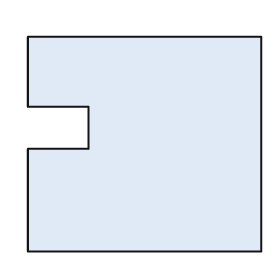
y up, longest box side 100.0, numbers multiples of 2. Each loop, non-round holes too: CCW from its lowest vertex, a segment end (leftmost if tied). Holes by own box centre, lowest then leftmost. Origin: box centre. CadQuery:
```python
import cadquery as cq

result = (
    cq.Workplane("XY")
    .moveTo(-50.0, -46.0)
    .lineTo(50.0, -46.0)
    .lineTo(50.0, 46.0)
    .lineTo(-50.0, 46.0)
    .lineTo(-50.0, 16.0)
    .lineTo(-24.0, 16.0)
    .lineTo(-24.0, -2.0)
    .lineTo(-50.0, -2.0)
    .close()
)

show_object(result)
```